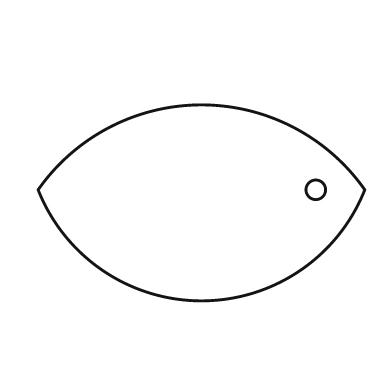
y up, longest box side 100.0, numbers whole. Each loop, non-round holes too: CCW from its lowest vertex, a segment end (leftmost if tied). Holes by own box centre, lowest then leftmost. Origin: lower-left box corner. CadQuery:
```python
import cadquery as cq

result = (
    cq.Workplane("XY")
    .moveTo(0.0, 34.0)
    .threePointArc((50.0, 0.0), (100.0, 34.0))
    .threePointArc((50.0, 60.0), (0.0, 34.0))
    .close()
    .moveTo(85.0, 34.0)
    .circle(3.0)
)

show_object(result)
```